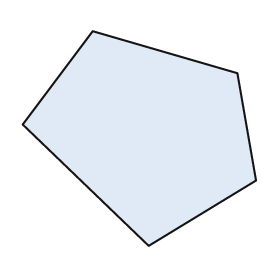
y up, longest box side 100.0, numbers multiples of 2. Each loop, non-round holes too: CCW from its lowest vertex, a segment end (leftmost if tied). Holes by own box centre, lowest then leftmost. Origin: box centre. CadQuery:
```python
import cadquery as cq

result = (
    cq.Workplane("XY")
    .moveTo(4.0, -46.0)
    .lineTo(50.0, -18.0)
    .lineTo(42.0, 28.0)
    .lineTo(-20.0, 46.0)
    .lineTo(-50.0, 6.0)
    .close()
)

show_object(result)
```